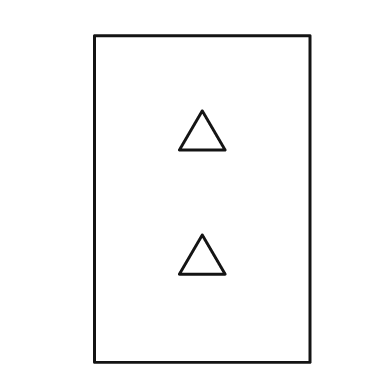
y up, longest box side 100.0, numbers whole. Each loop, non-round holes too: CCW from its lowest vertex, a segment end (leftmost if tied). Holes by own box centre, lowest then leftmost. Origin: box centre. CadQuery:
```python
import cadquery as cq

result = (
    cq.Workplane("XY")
    .moveTo(-33.0, -50.0)
    .lineTo(33.0, -50.0)
    .lineTo(33.0, 50.0)
    .lineTo(-33.0, 50.0)
    .close()
    .moveTo(-7.0, -23.0)
    .lineTo(7.0, -23.0)
    .lineTo(0.0, -11.0)
    .close()
    .moveTo(-7.0, 15.0)
    .lineTo(7.0, 15.0)
    .lineTo(0.0, 27.0)
    .close()
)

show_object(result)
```